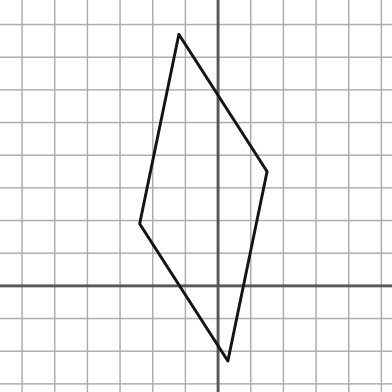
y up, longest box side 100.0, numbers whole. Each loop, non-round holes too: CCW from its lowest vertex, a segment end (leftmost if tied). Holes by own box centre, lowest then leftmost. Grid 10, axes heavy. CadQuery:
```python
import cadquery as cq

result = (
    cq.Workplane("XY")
    .moveTo(3.0, -23.0)
    .lineTo(15.0, 35.0)
    .lineTo(-12.0, 77.0)
    .lineTo(-24.0, 19.0)
    .close()
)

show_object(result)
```